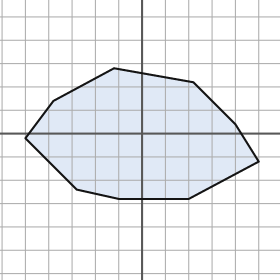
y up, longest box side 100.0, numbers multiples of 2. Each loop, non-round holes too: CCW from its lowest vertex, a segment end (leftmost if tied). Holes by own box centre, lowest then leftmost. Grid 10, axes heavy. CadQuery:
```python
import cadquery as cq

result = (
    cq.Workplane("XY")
    .moveTo(-10.0, -28.0)
    .lineTo(20.0, -28.0)
    .lineTo(50.0, -12.0)
    .lineTo(40.0, 4.0)
    .lineTo(22.0, 22.0)
    .lineTo(-12.0, 28.0)
    .lineTo(-38.0, 14.0)
    .lineTo(-50.0, -2.0)
    .lineTo(-28.0, -24.0)
    .close()
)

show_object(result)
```